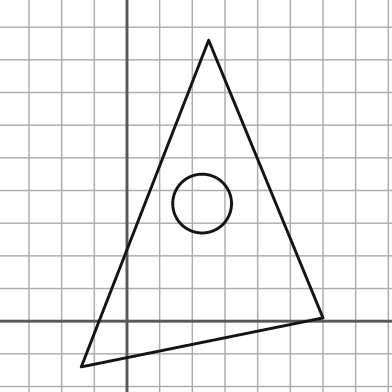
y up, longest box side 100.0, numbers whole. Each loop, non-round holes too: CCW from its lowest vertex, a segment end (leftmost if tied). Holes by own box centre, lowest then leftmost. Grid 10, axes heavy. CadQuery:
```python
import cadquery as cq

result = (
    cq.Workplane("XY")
    .moveTo(-14.0, -14.0)
    .lineTo(60.0, 1.0)
    .lineTo(25.0, 86.0)
    .close()
    .moveTo(23.0, 36.0)
    .circle(9.0)
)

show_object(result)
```